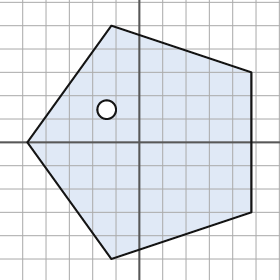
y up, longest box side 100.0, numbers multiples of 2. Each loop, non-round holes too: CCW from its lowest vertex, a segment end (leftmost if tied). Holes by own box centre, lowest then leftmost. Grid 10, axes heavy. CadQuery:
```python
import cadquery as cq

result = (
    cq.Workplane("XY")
    .moveTo(-12.0, -50.0)
    .lineTo(48.0, -30.0)
    .lineTo(48.0, 30.0)
    .lineTo(-12.0, 50.0)
    .lineTo(-48.0, 0.0)
    .close()
    .moveTo(-14.0, 14.0)
    .circle(4.0)
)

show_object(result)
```